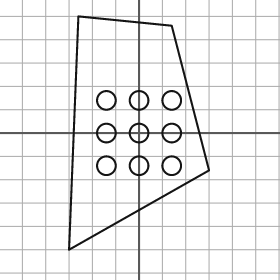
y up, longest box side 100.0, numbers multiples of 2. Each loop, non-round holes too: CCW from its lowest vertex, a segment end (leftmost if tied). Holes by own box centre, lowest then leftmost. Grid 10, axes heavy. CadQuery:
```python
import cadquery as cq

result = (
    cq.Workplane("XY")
    .moveTo(-30.0, -50.0)
    .lineTo(30.0, -16.0)
    .lineTo(14.0, 46.0)
    .lineTo(-26.0, 50.0)
    .close()
    .moveTo(-14.0, -14.0)
    .circle(4.0)
    .moveTo(0.0, -14.0)
    .circle(4.0)
    .moveTo(14.0, -14.0)
    .circle(4.0)
    .moveTo(-14.0, 0.0)
    .circle(4.0)
    .moveTo(0.0, 0.0)
    .circle(4.0)
    .moveTo(14.0, 0.0)
    .circle(4.0)
    .moveTo(-14.0, 14.0)
    .circle(4.0)
    .moveTo(0.0, 14.0)
    .circle(4.0)
    .moveTo(14.0, 14.0)
    .circle(4.0)
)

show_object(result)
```